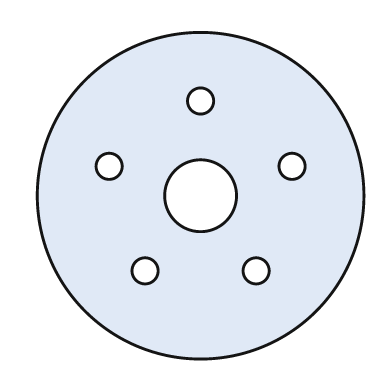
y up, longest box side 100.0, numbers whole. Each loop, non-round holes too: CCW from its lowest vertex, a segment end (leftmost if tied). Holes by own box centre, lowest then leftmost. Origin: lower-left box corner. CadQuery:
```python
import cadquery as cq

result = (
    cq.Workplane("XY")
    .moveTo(50.0, 50.0)
    .circle(50.0)
    .moveTo(33.0, 27.0)
    .circle(4.0)
    .moveTo(67.0, 27.0)
    .circle(4.0)
    .moveTo(50.0, 50.0)
    .circle(11.0)
    .moveTo(22.0, 59.0)
    .circle(4.0)
    .moveTo(78.0, 59.0)
    .circle(4.0)
    .moveTo(50.0, 79.0)
    .circle(4.0)
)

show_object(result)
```